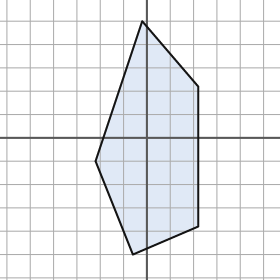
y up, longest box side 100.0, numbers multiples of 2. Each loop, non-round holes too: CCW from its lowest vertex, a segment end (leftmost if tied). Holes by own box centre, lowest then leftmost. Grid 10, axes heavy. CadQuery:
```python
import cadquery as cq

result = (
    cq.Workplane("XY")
    .moveTo(-6.0, -50.0)
    .lineTo(22.0, -38.0)
    .lineTo(22.0, 22.0)
    .lineTo(-2.0, 50.0)
    .lineTo(-22.0, -10.0)
    .close()
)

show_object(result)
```